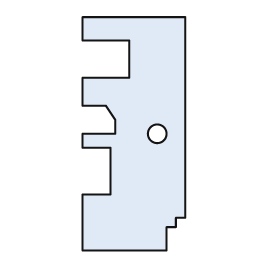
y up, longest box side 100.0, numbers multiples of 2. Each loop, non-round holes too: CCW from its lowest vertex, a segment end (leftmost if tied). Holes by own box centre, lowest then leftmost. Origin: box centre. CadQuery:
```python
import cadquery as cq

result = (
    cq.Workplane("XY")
    .moveTo(-22.0, -50.0)
    .lineTo(14.0, -50.0)
    .lineTo(14.0, -40.0)
    .lineTo(18.0, -40.0)
    .lineTo(18.0, -36.0)
    .lineTo(22.0, -36.0)
    .lineTo(22.0, 50.0)
    .lineTo(-22.0, 50.0)
    .lineTo(-22.0, 40.0)
    .lineTo(-2.0, 40.0)
    .lineTo(-2.0, 24.0)
    .lineTo(-22.0, 24.0)
    .lineTo(-22.0, 12.0)
    .lineTo(-12.0, 12.0)
    .lineTo(-8.0, 6.0)
    .lineTo(-8.0, 0.0)
    .lineTo(-22.0, 0.0)
    .lineTo(-22.0, -6.0)
    .lineTo(-10.0, -6.0)
    .lineTo(-10.0, -26.0)
    .lineTo(-22.0, -26.0)
    .close()
    .moveTo(10.0, 0.0)
    .circle(4.0)
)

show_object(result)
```